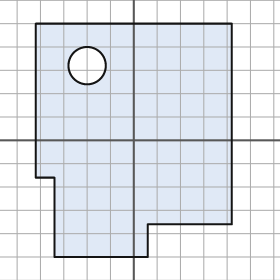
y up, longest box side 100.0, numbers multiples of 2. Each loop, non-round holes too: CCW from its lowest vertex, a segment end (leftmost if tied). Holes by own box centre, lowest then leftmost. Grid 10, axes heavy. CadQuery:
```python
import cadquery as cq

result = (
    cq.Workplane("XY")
    .moveTo(-34.0, -50.0)
    .lineTo(6.0, -50.0)
    .lineTo(6.0, -36.0)
    .lineTo(42.0, -36.0)
    .lineTo(42.0, 50.0)
    .lineTo(-42.0, 50.0)
    .lineTo(-42.0, -16.0)
    .lineTo(-34.0, -16.0)
    .close()
    .moveTo(-20.0, 32.0)
    .circle(8.0)
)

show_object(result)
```